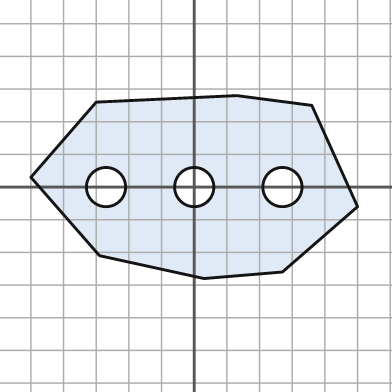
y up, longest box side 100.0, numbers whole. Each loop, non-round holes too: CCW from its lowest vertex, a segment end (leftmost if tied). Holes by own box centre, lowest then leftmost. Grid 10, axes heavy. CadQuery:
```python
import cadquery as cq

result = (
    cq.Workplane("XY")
    .moveTo(3.0, -28.0)
    .lineTo(27.0, -26.0)
    .lineTo(50.0, -6.0)
    .lineTo(36.0, 25.0)
    .lineTo(13.0, 28.0)
    .lineTo(-30.0, 26.0)
    .lineTo(-50.0, 3.0)
    .lineTo(-29.0, -21.0)
    .close()
    .moveTo(-27.0, 0.0)
    .circle(6.0)
    .moveTo(0.0, 0.0)
    .circle(6.0)
    .moveTo(27.0, 0.0)
    .circle(6.0)
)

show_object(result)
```